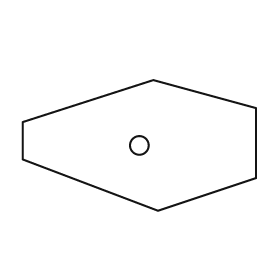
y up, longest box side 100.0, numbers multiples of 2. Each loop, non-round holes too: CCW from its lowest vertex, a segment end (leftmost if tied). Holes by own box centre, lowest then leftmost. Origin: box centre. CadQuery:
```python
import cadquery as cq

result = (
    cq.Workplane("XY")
    .moveTo(8.0, -28.0)
    .lineTo(50.0, -14.0)
    .lineTo(50.0, 16.0)
    .lineTo(6.0, 28.0)
    .lineTo(-50.0, 10.0)
    .lineTo(-50.0, -6.0)
    .close()
    .moveTo(0.0, 0.0)
    .circle(4.0)
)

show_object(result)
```